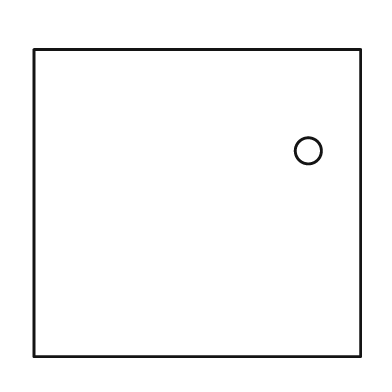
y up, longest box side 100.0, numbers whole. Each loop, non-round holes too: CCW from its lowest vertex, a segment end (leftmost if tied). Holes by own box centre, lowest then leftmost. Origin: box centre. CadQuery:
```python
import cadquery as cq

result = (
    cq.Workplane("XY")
    .moveTo(-50.0, -47.0)
    .lineTo(50.0, -47.0)
    .lineTo(50.0, 47.0)
    .lineTo(-50.0, 47.0)
    .close()
    .moveTo(34.0, 16.0)
    .circle(4.0)
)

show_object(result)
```